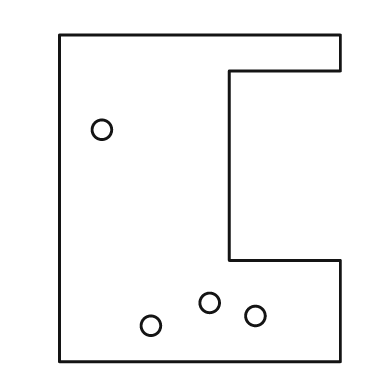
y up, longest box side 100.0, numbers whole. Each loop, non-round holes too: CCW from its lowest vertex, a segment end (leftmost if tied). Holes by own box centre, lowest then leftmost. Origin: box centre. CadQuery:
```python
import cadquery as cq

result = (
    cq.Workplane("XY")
    .moveTo(-43.0, -50.0)
    .lineTo(43.0, -50.0)
    .lineTo(43.0, -19.0)
    .lineTo(9.0, -19.0)
    .lineTo(9.0, 39.0)
    .lineTo(43.0, 39.0)
    .lineTo(43.0, 50.0)
    .lineTo(-43.0, 50.0)
    .close()
    .moveTo(-15.0, -39.0)
    .circle(3.0)
    .moveTo(17.0, -36.0)
    .circle(3.0)
    .moveTo(3.0, -32.0)
    .circle(3.0)
    .moveTo(-30.0, 21.0)
    .circle(3.0)
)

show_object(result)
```